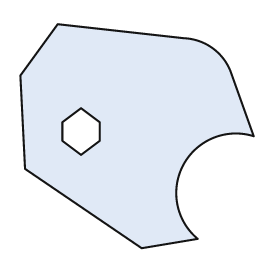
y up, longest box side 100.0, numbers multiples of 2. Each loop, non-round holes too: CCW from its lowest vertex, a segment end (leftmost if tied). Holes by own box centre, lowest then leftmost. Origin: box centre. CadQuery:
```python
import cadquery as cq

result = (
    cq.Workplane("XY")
    .moveTo(2.0, -48.0)
    .lineTo(26.0, -44.0)
    .threePointArc((20.0, -12.0), (50.0, 0.0))
    .lineTo(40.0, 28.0)
    .threePointArc((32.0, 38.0), (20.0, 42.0))
    .lineTo(-34.0, 48.0)
    .lineTo(-50.0, 26.0)
    .lineTo(-48.0, -14.0)
    .close()
    .moveTo(-24.0, -8.0)
    .lineTo(-16.0, -2.0)
    .lineTo(-16.0, 6.0)
    .lineTo(-24.0, 12.0)
    .lineTo(-32.0, 6.0)
    .lineTo(-32.0, -2.0)
    .close()
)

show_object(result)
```